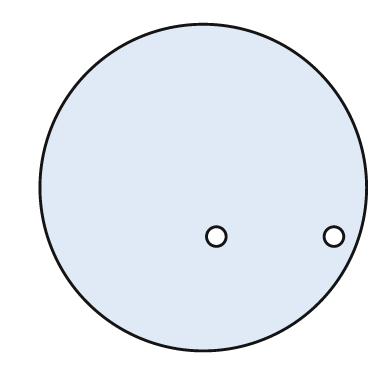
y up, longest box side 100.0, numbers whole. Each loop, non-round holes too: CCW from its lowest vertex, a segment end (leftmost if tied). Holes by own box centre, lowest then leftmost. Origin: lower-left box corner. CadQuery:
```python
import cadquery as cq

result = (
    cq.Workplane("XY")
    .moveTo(50.0, 50.0)
    .circle(50.0)
    .moveTo(54.0, 35.0)
    .circle(3.0)
    .moveTo(90.0, 35.0)
    .circle(3.0)
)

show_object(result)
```